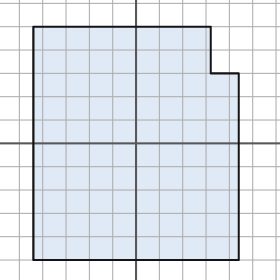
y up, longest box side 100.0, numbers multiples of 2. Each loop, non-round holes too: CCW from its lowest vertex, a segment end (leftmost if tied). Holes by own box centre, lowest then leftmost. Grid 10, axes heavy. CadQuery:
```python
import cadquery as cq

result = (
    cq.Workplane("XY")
    .moveTo(-44.0, -50.0)
    .lineTo(44.0, -50.0)
    .lineTo(44.0, 30.0)
    .lineTo(32.0, 30.0)
    .lineTo(32.0, 50.0)
    .lineTo(-44.0, 50.0)
    .close()
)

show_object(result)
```